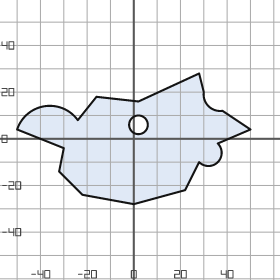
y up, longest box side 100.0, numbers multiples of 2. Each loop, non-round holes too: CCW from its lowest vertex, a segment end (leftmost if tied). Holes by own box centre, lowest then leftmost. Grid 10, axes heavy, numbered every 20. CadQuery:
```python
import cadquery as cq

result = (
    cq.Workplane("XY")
    .moveTo(0.0, -28.0)
    .lineTo(22.0, -22.0)
    .lineTo(28.0, -10.0)
    .threePointArc((36.0, -10.0), (36.0, -2.0))
    .lineTo(50.0, 4.0)
    .lineTo(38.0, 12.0)
    .threePointArc((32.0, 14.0), (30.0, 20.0))
    .lineTo(28.0, 28.0)
    .lineTo(2.0, 16.0)
    .lineTo(-16.0, 18.0)
    .lineTo(-24.0, 8.0)
    .threePointArc((-38.0, 14.0), (-50.0, 4.0))
    .lineTo(-30.0, -4.0)
    .lineTo(-32.0, -14.0)
    .lineTo(-22.0, -24.0)
    .close()
    .moveTo(2.0, 6.0)
    .circle(4.0)
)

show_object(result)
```